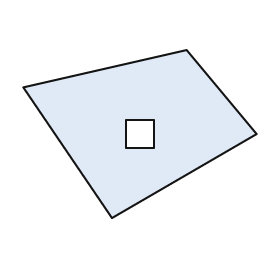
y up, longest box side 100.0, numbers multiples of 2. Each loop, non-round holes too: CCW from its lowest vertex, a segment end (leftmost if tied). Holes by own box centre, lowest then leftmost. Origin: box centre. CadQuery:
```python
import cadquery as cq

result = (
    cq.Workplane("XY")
    .moveTo(-12.0, -36.0)
    .lineTo(50.0, 0.0)
    .lineTo(20.0, 36.0)
    .lineTo(-50.0, 20.0)
    .close()
    .moveTo(-6.0, -6.0)
    .lineTo(6.0, -6.0)
    .lineTo(6.0, 6.0)
    .lineTo(-6.0, 6.0)
    .close()
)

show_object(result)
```